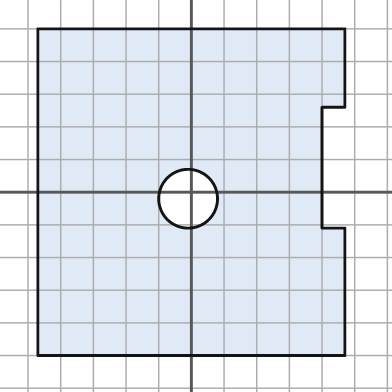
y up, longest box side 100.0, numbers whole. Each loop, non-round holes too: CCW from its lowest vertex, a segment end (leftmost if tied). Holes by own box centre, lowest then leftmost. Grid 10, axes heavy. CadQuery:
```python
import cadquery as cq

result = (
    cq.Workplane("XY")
    .moveTo(-47.0, -50.0)
    .lineTo(47.0, -50.0)
    .lineTo(47.0, -11.0)
    .lineTo(40.0, -11.0)
    .lineTo(40.0, 26.0)
    .lineTo(47.0, 26.0)
    .lineTo(47.0, 50.0)
    .lineTo(-47.0, 50.0)
    .close()
    .moveTo(-1.0, -2.0)
    .circle(9.0)
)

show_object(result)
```